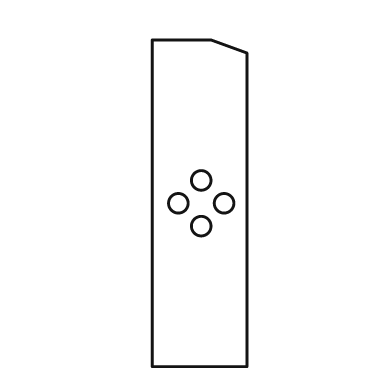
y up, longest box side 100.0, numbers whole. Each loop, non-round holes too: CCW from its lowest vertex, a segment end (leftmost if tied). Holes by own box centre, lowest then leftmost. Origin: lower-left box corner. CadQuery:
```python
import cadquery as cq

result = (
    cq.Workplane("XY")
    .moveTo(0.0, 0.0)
    .lineTo(29.0, 0.0)
    .lineTo(29.0, 96.0)
    .lineTo(18.0, 100.0)
    .lineTo(0.0, 100.0)
    .close()
    .moveTo(15.0, 43.0)
    .circle(3.0)
    .moveTo(8.0, 50.0)
    .circle(3.0)
    .moveTo(22.0, 50.0)
    .circle(3.0)
    .moveTo(15.0, 57.0)
    .circle(3.0)
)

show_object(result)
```